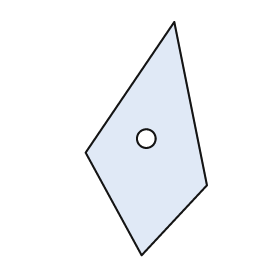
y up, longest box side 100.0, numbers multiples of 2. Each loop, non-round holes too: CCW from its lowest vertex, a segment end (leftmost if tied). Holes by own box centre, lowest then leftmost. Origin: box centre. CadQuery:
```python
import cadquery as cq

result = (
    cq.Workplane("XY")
    .moveTo(-2.0, -50.0)
    .lineTo(26.0, -20.0)
    .lineTo(12.0, 50.0)
    .lineTo(-26.0, -6.0)
    .close()
    .moveTo(0.0, 0.0)
    .circle(4.0)
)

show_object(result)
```